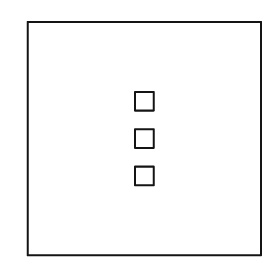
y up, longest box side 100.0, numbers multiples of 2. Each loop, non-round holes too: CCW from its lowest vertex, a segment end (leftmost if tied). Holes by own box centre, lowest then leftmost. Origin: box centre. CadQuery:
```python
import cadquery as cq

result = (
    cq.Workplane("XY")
    .moveTo(-50.0, -50.0)
    .lineTo(50.0, -50.0)
    .lineTo(50.0, 50.0)
    .lineTo(-50.0, 50.0)
    .close()
    .moveTo(-4.0, -20.0)
    .lineTo(4.0, -20.0)
    .lineTo(4.0, -12.0)
    .lineTo(-4.0, -12.0)
    .close()
    .moveTo(-4.0, -4.0)
    .lineTo(4.0, -4.0)
    .lineTo(4.0, 4.0)
    .lineTo(-4.0, 4.0)
    .close()
    .moveTo(-4.0, 12.0)
    .lineTo(4.0, 12.0)
    .lineTo(4.0, 20.0)
    .lineTo(-4.0, 20.0)
    .close()
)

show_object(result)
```